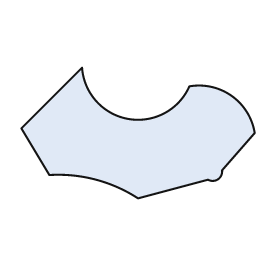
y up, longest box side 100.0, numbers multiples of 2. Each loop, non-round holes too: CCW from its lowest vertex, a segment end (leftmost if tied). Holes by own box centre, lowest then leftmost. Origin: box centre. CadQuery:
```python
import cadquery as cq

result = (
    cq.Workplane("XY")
    .moveTo(0.0, -28.0)
    .lineTo(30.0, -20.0)
    .threePointArc((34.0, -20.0), (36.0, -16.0))
    .lineTo(50.0, 0.0)
    .threePointArc((40.0, 16.0), (22.0, 20.0))
    .threePointArc((-4.0, 6.0), (-24.0, 28.0))
    .lineTo(-50.0, 2.0)
    .lineTo(-38.0, -18.0)
    .threePointArc((-18.0, -20.0), (0.0, -28.0))
    .close()
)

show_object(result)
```